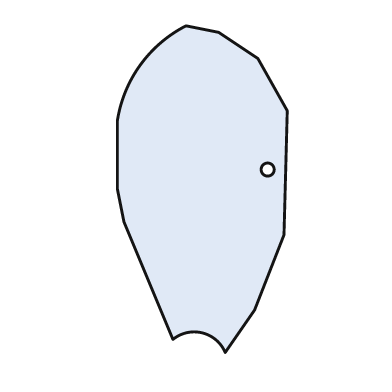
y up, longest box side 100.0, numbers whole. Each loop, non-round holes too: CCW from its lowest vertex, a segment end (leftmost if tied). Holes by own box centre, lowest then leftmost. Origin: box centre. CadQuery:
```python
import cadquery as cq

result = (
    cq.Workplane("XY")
    .moveTo(7.0, -50.0)
    .lineTo(16.0, -37.0)
    .lineTo(25.0, -14.0)
    .lineTo(26.0, 24.0)
    .lineTo(17.0, 40.0)
    .lineTo(5.0, 48.0)
    .lineTo(-5.0, 50.0)
    .threePointArc((-19.0, 38.0), (-26.0, 21.0))
    .lineTo(-26.0, 0.0)
    .lineTo(-24.0, -10.0)
    .lineTo(-9.0, -46.0)
    .threePointArc((0.0, -44.0), (7.0, -50.0))
    .close()
    .moveTo(20.0, 6.0)
    .circle(2.0)
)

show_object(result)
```